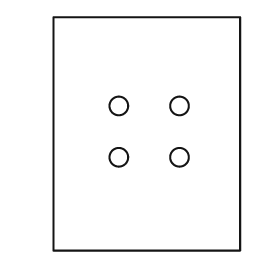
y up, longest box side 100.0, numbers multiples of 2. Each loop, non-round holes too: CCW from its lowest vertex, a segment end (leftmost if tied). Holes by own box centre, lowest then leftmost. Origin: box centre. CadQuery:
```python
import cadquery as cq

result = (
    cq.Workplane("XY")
    .moveTo(-40.0, -50.0)
    .lineTo(40.0, -50.0)
    .lineTo(40.0, 50.0)
    .lineTo(-40.0, 50.0)
    .close()
    .moveTo(-12.0, -10.0)
    .circle(4.0)
    .moveTo(14.0, -10.0)
    .circle(4.0)
    .moveTo(-12.0, 12.0)
    .circle(4.0)
    .moveTo(14.0, 12.0)
    .circle(4.0)
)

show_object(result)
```